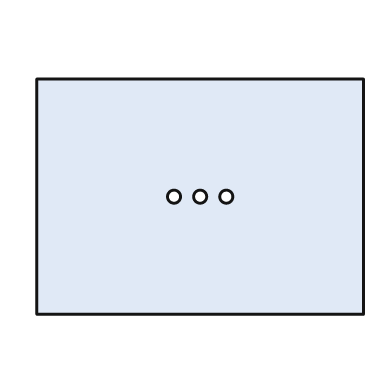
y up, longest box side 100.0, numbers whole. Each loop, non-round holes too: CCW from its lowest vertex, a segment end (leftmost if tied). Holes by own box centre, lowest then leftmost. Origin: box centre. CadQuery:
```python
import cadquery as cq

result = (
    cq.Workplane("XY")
    .moveTo(-50.0, -36.0)
    .lineTo(50.0, -36.0)
    .lineTo(50.0, 36.0)
    .lineTo(-50.0, 36.0)
    .close()
    .moveTo(-8.0, 0.0)
    .circle(2.0)
    .moveTo(0.0, 0.0)
    .circle(2.0)
    .moveTo(8.0, 0.0)
    .circle(2.0)
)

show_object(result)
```